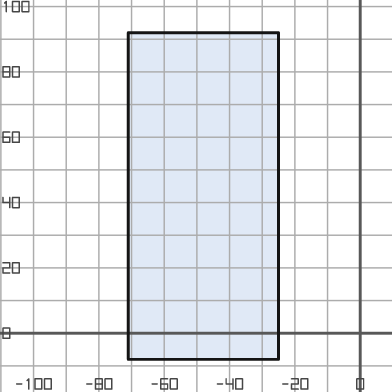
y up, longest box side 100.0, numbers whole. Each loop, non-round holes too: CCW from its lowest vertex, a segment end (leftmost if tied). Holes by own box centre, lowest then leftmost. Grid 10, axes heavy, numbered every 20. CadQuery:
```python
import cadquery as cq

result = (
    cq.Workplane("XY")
    .moveTo(-71.0, -8.0)
    .lineTo(-25.0, -8.0)
    .lineTo(-25.0, 92.0)
    .lineTo(-71.0, 92.0)
    .close()
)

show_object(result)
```